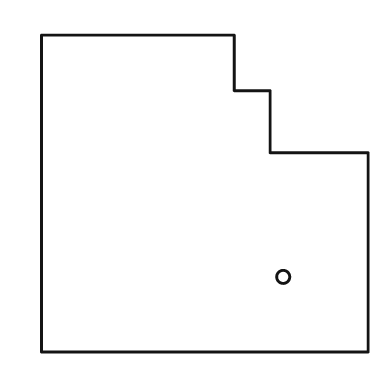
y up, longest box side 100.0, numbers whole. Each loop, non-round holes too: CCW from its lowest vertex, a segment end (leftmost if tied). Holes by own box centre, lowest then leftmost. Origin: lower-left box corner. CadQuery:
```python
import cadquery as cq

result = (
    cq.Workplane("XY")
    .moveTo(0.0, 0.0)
    .lineTo(100.0, 0.0)
    .lineTo(100.0, 61.0)
    .lineTo(70.0, 61.0)
    .lineTo(70.0, 80.0)
    .lineTo(59.0, 80.0)
    .lineTo(59.0, 97.0)
    .lineTo(0.0, 97.0)
    .close()
    .moveTo(74.0, 23.0)
    .circle(2.0)
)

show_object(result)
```